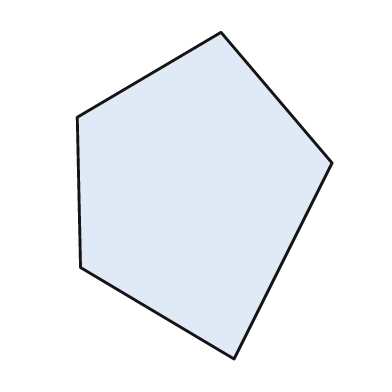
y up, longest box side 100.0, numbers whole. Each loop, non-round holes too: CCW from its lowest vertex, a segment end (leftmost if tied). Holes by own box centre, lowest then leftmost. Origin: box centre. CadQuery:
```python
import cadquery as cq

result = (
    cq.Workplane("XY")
    .moveTo(9.0, -50.0)
    .lineTo(39.0, 10.0)
    .lineTo(5.0, 50.0)
    .lineTo(-39.0, 24.0)
    .lineTo(-38.0, -22.0)
    .close()
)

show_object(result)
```